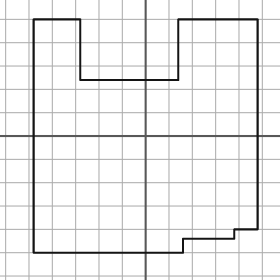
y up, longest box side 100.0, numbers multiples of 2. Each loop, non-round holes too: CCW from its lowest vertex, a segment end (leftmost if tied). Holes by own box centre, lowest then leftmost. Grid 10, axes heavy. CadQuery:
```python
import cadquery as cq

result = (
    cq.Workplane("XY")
    .moveTo(-48.0, -50.0)
    .lineTo(16.0, -50.0)
    .lineTo(16.0, -44.0)
    .lineTo(38.0, -44.0)
    .lineTo(38.0, -40.0)
    .lineTo(48.0, -40.0)
    .lineTo(48.0, 50.0)
    .lineTo(14.0, 50.0)
    .lineTo(14.0, 24.0)
    .lineTo(-28.0, 24.0)
    .lineTo(-28.0, 50.0)
    .lineTo(-48.0, 50.0)
    .close()
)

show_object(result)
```